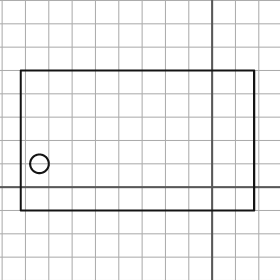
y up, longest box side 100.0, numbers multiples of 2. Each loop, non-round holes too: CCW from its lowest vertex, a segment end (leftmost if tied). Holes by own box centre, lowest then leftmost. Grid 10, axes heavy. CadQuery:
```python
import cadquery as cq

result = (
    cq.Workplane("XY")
    .moveTo(-82.0, -10.0)
    .lineTo(18.0, -10.0)
    .lineTo(18.0, 50.0)
    .lineTo(-82.0, 50.0)
    .close()
    .moveTo(-74.0, 10.0)
    .circle(4.0)
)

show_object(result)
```